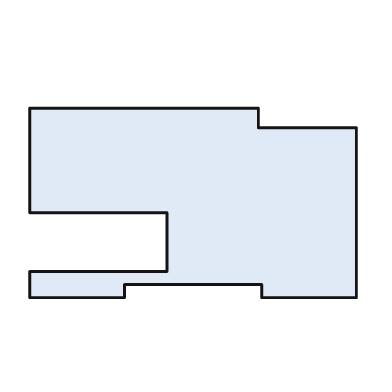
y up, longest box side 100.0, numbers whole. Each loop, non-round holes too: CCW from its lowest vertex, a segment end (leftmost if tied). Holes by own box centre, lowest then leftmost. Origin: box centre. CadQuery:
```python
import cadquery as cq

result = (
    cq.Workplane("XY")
    .moveTo(-50.0, -29.0)
    .lineTo(-21.0, -29.0)
    .lineTo(-21.0, -25.0)
    .lineTo(21.0, -25.0)
    .lineTo(21.0, -29.0)
    .lineTo(50.0, -29.0)
    .lineTo(50.0, 23.0)
    .lineTo(20.0, 23.0)
    .lineTo(20.0, 29.0)
    .lineTo(-50.0, 29.0)
    .lineTo(-50.0, -3.0)
    .lineTo(-8.0, -3.0)
    .lineTo(-8.0, -21.0)
    .lineTo(-50.0, -21.0)
    .close()
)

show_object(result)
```